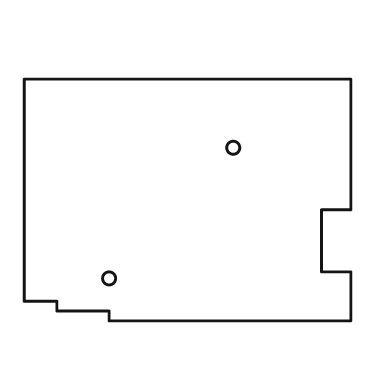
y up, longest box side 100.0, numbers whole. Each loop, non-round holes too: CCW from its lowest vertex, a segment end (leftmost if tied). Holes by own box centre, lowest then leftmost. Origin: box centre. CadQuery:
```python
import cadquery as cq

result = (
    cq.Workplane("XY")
    .moveTo(-24.0, -37.0)
    .lineTo(50.0, -37.0)
    .lineTo(50.0, -22.0)
    .lineTo(41.0, -22.0)
    .lineTo(41.0, -3.0)
    .lineTo(50.0, -3.0)
    .lineTo(50.0, 37.0)
    .lineTo(-50.0, 37.0)
    .lineTo(-50.0, -31.0)
    .lineTo(-40.0, -31.0)
    .lineTo(-40.0, -34.0)
    .lineTo(-24.0, -34.0)
    .close()
    .moveTo(-24.0, -24.0)
    .circle(2.0)
    .moveTo(14.0, 16.0)
    .circle(2.0)
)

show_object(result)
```